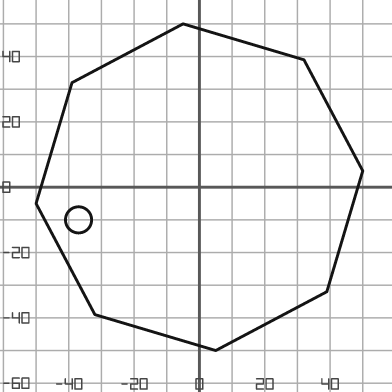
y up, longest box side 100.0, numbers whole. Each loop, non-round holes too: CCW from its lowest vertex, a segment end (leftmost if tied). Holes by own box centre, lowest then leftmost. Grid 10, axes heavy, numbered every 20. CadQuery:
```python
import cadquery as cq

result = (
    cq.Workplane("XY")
    .moveTo(5.0, -50.0)
    .lineTo(39.0, -32.0)
    .lineTo(50.0, 5.0)
    .lineTo(32.0, 39.0)
    .lineTo(-5.0, 50.0)
    .lineTo(-39.0, 32.0)
    .lineTo(-50.0, -5.0)
    .lineTo(-32.0, -39.0)
    .close()
    .moveTo(-37.0, -10.0)
    .circle(4.0)
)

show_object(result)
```